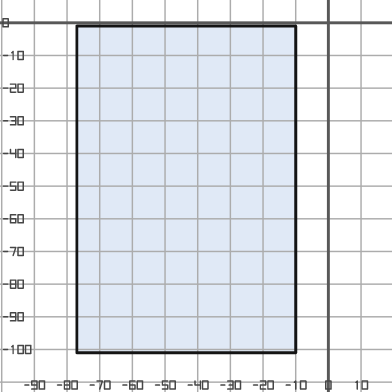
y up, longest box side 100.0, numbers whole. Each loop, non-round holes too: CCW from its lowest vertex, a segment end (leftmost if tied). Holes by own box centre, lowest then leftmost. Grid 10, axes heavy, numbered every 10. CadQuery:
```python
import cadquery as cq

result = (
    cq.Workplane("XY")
    .moveTo(-77.0, -101.0)
    .lineTo(-10.0, -101.0)
    .lineTo(-10.0, -1.0)
    .lineTo(-77.0, -1.0)
    .close()
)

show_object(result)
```